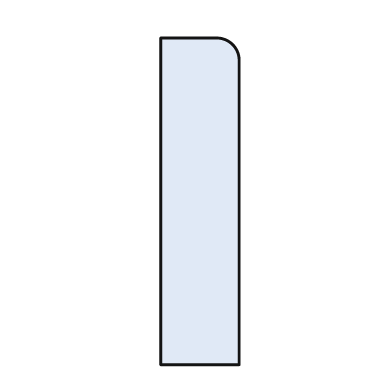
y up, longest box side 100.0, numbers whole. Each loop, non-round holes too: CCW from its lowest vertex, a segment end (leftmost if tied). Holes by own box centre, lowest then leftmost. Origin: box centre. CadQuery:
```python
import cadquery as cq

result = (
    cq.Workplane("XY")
    .moveTo(-12.0, -50.0)
    .lineTo(12.0, -50.0)
    .lineTo(12.0, 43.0)
    .threePointArc((10.0, 48.0), (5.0, 50.0))
    .lineTo(-12.0, 50.0)
    .close()
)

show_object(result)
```